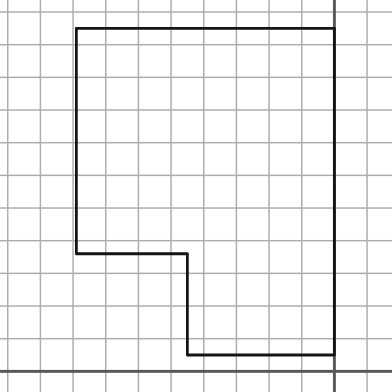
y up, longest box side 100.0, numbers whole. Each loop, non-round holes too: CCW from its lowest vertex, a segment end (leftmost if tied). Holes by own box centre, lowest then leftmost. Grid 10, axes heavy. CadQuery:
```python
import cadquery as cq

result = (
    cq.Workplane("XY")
    .moveTo(-45.0, 5.0)
    .lineTo(0.0, 5.0)
    .lineTo(0.0, 105.0)
    .lineTo(-79.0, 105.0)
    .lineTo(-79.0, 36.0)
    .lineTo(-45.0, 36.0)
    .close()
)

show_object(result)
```